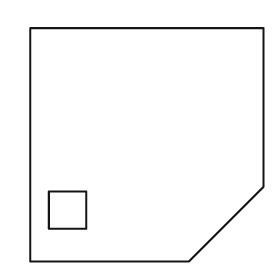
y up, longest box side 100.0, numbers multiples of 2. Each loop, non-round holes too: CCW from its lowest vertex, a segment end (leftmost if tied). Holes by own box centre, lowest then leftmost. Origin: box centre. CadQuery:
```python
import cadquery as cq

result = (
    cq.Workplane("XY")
    .moveTo(-50.0, -50.0)
    .lineTo(18.0, -50.0)
    .lineTo(50.0, -18.0)
    .lineTo(50.0, 50.0)
    .lineTo(-50.0, 50.0)
    .close()
    .moveTo(-42.0, -36.0)
    .lineTo(-26.0, -36.0)
    .lineTo(-26.0, -20.0)
    .lineTo(-42.0, -20.0)
    .close()
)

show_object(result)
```